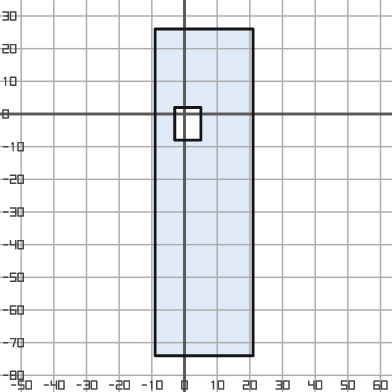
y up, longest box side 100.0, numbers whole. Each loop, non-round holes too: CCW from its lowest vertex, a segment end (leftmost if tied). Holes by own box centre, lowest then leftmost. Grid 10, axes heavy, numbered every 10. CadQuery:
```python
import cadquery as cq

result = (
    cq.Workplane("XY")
    .moveTo(-9.0, -74.0)
    .lineTo(21.0, -74.0)
    .lineTo(21.0, 26.0)
    .lineTo(-9.0, 26.0)
    .close()
    .moveTo(-3.0, -8.0)
    .lineTo(5.0, -8.0)
    .lineTo(5.0, 2.0)
    .lineTo(-3.0, 2.0)
    .close()
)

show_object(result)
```